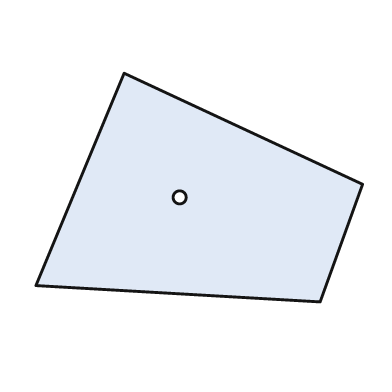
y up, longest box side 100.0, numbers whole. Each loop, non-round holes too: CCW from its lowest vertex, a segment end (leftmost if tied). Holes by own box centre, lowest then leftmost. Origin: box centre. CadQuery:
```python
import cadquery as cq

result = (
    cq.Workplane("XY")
    .moveTo(37.0, -35.0)
    .lineTo(50.0, 1.0)
    .lineTo(-23.0, 35.0)
    .lineTo(-50.0, -30.0)
    .close()
    .moveTo(-6.0, -3.0)
    .circle(2.0)
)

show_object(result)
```